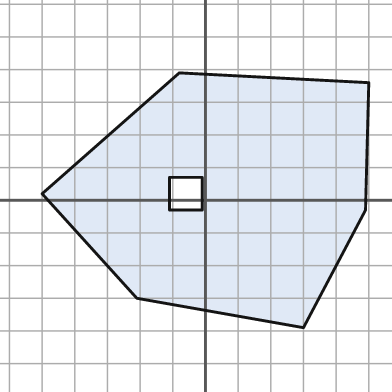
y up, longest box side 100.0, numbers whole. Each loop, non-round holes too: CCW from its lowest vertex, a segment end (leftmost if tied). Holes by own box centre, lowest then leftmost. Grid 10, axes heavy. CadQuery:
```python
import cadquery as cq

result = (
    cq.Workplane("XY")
    .moveTo(30.0, -39.0)
    .lineTo(49.0, -3.0)
    .lineTo(50.0, 36.0)
    .lineTo(-8.0, 39.0)
    .lineTo(-50.0, 2.0)
    .lineTo(-21.0, -30.0)
    .close()
    .moveTo(-11.0, -3.0)
    .lineTo(-1.0, -3.0)
    .lineTo(-1.0, 7.0)
    .lineTo(-11.0, 7.0)
    .close()
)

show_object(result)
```